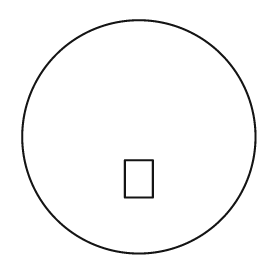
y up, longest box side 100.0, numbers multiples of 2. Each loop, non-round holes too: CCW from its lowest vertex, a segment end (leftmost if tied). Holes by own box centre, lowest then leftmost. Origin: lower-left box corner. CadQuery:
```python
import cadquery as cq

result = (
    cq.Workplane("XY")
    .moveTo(50.0, 50.0)
    .circle(50.0)
    .moveTo(44.0, 24.0)
    .lineTo(56.0, 24.0)
    .lineTo(56.0, 40.0)
    .lineTo(44.0, 40.0)
    .close()
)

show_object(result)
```